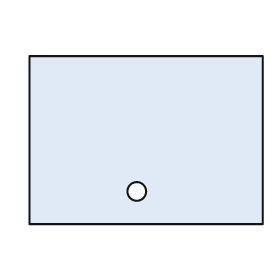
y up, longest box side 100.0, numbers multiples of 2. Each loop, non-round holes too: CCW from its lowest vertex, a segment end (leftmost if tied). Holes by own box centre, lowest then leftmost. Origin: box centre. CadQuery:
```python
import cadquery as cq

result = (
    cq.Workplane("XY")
    .moveTo(-50.0, -36.0)
    .lineTo(50.0, -36.0)
    .lineTo(50.0, 36.0)
    .lineTo(-50.0, 36.0)
    .close()
    .moveTo(-4.0, -22.0)
    .circle(4.0)
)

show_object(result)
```